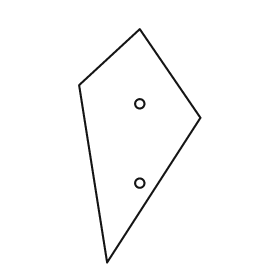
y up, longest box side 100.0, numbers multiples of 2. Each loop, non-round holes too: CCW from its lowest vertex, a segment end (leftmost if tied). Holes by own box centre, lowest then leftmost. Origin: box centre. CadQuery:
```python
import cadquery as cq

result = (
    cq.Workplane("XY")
    .moveTo(-14.0, -50.0)
    .lineTo(26.0, 12.0)
    .lineTo(0.0, 50.0)
    .lineTo(-26.0, 26.0)
    .close()
    .moveTo(0.0, -16.0)
    .circle(2.0)
    .moveTo(0.0, 18.0)
    .circle(2.0)
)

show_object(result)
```